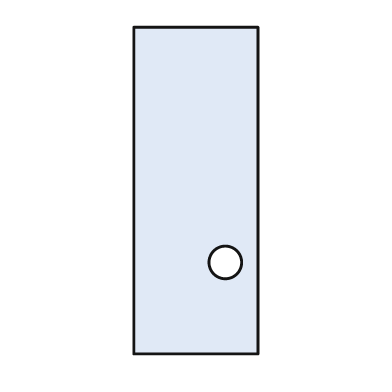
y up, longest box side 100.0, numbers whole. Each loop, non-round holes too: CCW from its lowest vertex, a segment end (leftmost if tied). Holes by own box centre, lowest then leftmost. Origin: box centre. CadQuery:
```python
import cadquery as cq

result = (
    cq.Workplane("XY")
    .moveTo(-19.0, -50.0)
    .lineTo(19.0, -50.0)
    .lineTo(19.0, 50.0)
    .lineTo(-19.0, 50.0)
    .close()
    .moveTo(9.0, -22.0)
    .circle(5.0)
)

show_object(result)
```